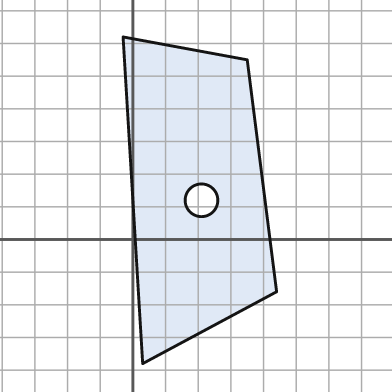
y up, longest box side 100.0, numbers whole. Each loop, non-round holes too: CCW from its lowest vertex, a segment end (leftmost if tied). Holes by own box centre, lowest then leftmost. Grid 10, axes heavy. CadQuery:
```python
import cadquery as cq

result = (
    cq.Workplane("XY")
    .moveTo(3.0, -38.0)
    .lineTo(44.0, -16.0)
    .lineTo(35.0, 55.0)
    .lineTo(-3.0, 62.0)
    .close()
    .moveTo(21.0, 12.0)
    .circle(5.0)
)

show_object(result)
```